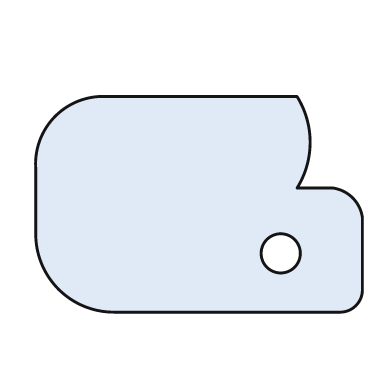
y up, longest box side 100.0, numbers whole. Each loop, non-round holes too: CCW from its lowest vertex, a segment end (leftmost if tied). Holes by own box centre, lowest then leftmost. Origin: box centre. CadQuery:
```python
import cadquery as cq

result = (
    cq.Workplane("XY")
    .moveTo(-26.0, -33.0)
    .lineTo(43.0, -33.0)
    .threePointArc((48.0, -31.0), (50.0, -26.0))
    .lineTo(50.0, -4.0)
    .threePointArc((47.0, 2.0), (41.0, 5.0))
    .lineTo(30.0, 5.0)
    .threePointArc((34.0, 19.0), (30.0, 33.0))
    .lineTo(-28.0, 33.0)
    .threePointArc((-44.0, 27.0), (-50.0, 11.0))
    .lineTo(-50.0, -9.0)
    .threePointArc((-43.0, -26.0), (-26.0, -33.0))
    .close()
    .moveTo(25.0, -15.0)
    .circle(6.0)
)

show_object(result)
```